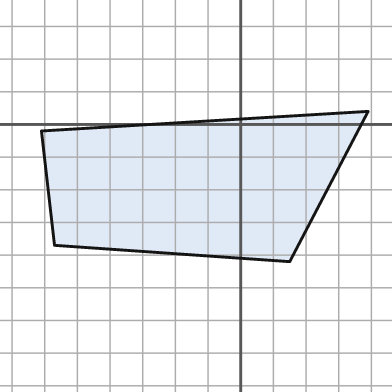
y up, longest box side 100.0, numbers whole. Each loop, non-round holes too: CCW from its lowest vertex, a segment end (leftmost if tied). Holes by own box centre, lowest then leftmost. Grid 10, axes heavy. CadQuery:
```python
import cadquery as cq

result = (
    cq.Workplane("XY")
    .moveTo(15.0, -42.0)
    .lineTo(39.0, 4.0)
    .lineTo(-61.0, -2.0)
    .lineTo(-57.0, -37.0)
    .close()
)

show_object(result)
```